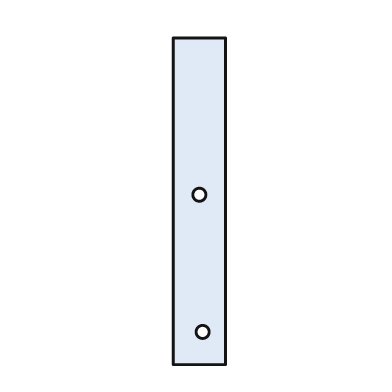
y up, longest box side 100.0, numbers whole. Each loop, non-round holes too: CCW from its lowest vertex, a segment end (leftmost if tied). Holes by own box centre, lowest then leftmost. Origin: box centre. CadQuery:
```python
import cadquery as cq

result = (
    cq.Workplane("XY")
    .moveTo(-8.0, -50.0)
    .lineTo(8.0, -50.0)
    .lineTo(8.0, 50.0)
    .lineTo(-8.0, 50.0)
    .close()
    .moveTo(1.0, -40.0)
    .circle(2.0)
    .moveTo(0.0, 2.0)
    .circle(2.0)
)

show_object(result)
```